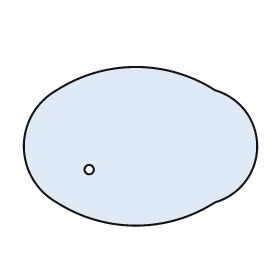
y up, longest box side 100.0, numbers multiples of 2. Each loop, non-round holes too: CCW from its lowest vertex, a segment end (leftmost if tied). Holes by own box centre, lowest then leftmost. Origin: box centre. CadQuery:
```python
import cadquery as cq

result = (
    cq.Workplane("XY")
    .moveTo(-36.0, -24.0)
    .threePointArc((-2.0, -34.0), (32.0, -24.0))
    .threePointArc((50.0, 0.0), (32.0, 24.0))
    .threePointArc((-2.0, 34.0), (-36.0, 24.0))
    .threePointArc((-50.0, 0.0), (-36.0, -24.0))
    .close()
    .moveTo(-22.0, -10.0)
    .circle(2.0)
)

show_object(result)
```